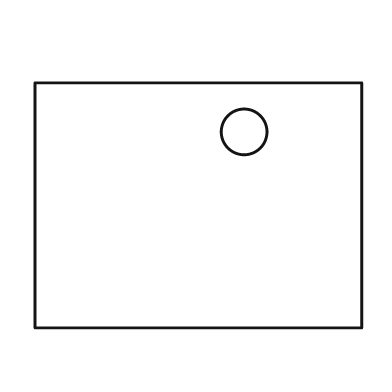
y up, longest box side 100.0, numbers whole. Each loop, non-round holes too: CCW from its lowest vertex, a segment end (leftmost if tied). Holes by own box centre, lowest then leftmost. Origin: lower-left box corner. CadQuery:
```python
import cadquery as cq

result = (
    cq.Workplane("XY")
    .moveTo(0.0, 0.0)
    .lineTo(100.0, 0.0)
    .lineTo(100.0, 75.0)
    .lineTo(0.0, 75.0)
    .close()
    .moveTo(64.0, 60.0)
    .circle(7.0)
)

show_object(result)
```